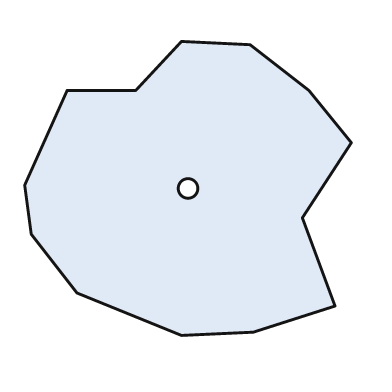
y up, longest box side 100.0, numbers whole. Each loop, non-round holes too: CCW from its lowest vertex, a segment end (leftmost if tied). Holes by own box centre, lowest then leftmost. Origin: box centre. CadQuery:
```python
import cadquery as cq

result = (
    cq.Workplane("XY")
    .moveTo(-2.0, -45.0)
    .lineTo(20.0, -44.0)
    .lineTo(45.0, -36.0)
    .lineTo(35.0, -9.0)
    .lineTo(50.0, 14.0)
    .lineTo(37.0, 30.0)
    .lineTo(19.0, 44.0)
    .lineTo(-2.0, 45.0)
    .lineTo(-16.0, 30.0)
    .lineTo(-37.0, 30.0)
    .lineTo(-50.0, 1.0)
    .lineTo(-48.0, -14.0)
    .lineTo(-34.0, -32.0)
    .close()
    .moveTo(0.0, 0.0)
    .circle(3.0)
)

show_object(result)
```